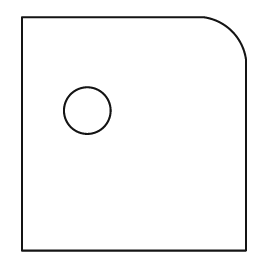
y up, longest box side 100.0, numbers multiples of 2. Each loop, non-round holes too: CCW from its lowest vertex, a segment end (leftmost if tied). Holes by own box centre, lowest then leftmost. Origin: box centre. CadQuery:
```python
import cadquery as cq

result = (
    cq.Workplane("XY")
    .moveTo(-48.0, -50.0)
    .lineTo(48.0, -50.0)
    .lineTo(48.0, 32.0)
    .threePointArc((42.0, 44.0), (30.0, 50.0))
    .lineTo(-48.0, 50.0)
    .close()
    .moveTo(-20.0, 10.0)
    .circle(10.0)
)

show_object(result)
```